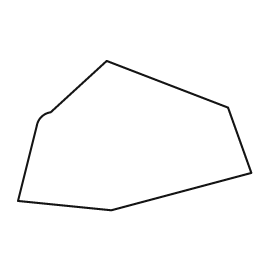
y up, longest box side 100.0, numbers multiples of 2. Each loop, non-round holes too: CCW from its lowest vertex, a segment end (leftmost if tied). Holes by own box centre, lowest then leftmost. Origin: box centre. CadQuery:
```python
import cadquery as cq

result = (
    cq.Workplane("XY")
    .moveTo(-10.0, -32.0)
    .lineTo(50.0, -16.0)
    .lineTo(40.0, 12.0)
    .lineTo(-12.0, 32.0)
    .lineTo(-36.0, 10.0)
    .threePointArc((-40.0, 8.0), (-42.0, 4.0))
    .lineTo(-50.0, -28.0)
    .close()
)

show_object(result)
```